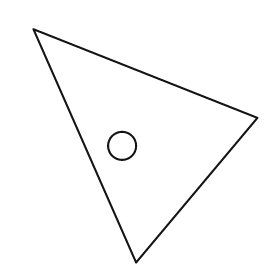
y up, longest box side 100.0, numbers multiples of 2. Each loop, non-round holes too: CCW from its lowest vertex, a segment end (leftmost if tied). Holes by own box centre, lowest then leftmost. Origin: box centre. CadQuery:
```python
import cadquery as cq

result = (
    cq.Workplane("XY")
    .moveTo(-4.0, -50.0)
    .lineTo(48.0, 12.0)
    .lineTo(-48.0, 50.0)
    .close()
    .moveTo(-10.0, 0.0)
    .circle(6.0)
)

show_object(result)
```